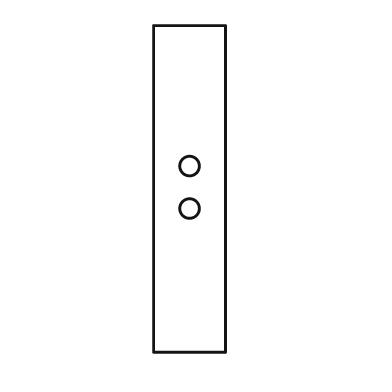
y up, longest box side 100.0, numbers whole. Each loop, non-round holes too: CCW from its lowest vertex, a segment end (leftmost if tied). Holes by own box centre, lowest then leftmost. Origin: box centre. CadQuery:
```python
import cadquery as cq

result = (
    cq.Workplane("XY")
    .moveTo(-11.0, -50.0)
    .lineTo(11.0, -50.0)
    .lineTo(11.0, 50.0)
    .lineTo(-11.0, 50.0)
    .close()
    .moveTo(0.0, -6.0)
    .circle(3.0)
    .moveTo(0.0, 7.0)
    .circle(3.0)
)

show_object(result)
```